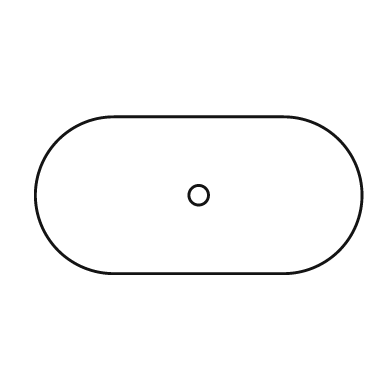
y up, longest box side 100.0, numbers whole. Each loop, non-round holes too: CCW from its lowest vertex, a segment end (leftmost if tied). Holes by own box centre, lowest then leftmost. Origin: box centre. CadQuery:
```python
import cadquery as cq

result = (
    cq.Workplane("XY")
    .moveTo(-26.0, -24.0)
    .lineTo(26.0, -24.0)
    .threePointArc((50.0, 0.0), (26.0, 24.0))
    .lineTo(-26.0, 24.0)
    .threePointArc((-50.0, 0.0), (-26.0, -24.0))
    .close()
    .moveTo(0.0, 0.0)
    .circle(3.0)
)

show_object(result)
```